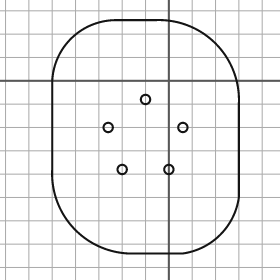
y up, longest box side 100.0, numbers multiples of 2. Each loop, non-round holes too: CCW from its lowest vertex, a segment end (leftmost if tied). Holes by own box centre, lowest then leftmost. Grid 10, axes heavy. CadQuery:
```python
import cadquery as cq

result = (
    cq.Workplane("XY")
    .moveTo(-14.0, -74.0)
    .lineTo(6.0, -74.0)
    .threePointArc((22.0, -66.0), (30.0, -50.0))
    .lineTo(30.0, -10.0)
    .threePointArc((20.0, 16.0), (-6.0, 26.0))
    .lineTo(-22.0, 26.0)
    .threePointArc((-42.0, 18.0), (-50.0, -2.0))
    .lineTo(-50.0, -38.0)
    .threePointArc((-40.0, -64.0), (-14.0, -74.0))
    .close()
    .moveTo(-20.0, -38.0)
    .circle(2.0)
    .moveTo(0.0, -38.0)
    .circle(2.0)
    .moveTo(-26.0, -20.0)
    .circle(2.0)
    .moveTo(6.0, -20.0)
    .circle(2.0)
    .moveTo(-10.0, -8.0)
    .circle(2.0)
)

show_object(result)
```